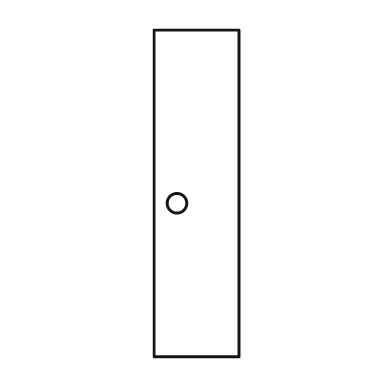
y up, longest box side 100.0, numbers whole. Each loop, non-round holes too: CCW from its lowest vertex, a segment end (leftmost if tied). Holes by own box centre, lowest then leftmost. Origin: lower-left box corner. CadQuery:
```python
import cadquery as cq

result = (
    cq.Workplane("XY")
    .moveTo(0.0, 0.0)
    .lineTo(26.0, 0.0)
    .lineTo(26.0, 100.0)
    .lineTo(0.0, 100.0)
    .close()
    .moveTo(7.0, 47.0)
    .circle(3.0)
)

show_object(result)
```